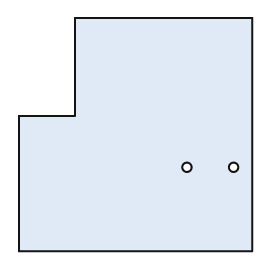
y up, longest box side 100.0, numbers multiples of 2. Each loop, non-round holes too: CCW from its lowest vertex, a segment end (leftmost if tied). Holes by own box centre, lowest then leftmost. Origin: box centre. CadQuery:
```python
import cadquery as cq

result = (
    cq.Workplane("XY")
    .moveTo(-50.0, -50.0)
    .lineTo(50.0, -50.0)
    .lineTo(50.0, 50.0)
    .lineTo(-26.0, 50.0)
    .lineTo(-26.0, 8.0)
    .lineTo(-50.0, 8.0)
    .close()
    .moveTo(22.0, -14.0)
    .circle(2.0)
    .moveTo(42.0, -14.0)
    .circle(2.0)
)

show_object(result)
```